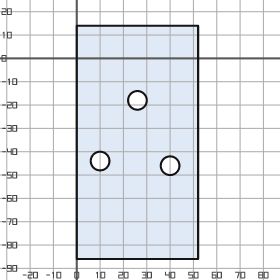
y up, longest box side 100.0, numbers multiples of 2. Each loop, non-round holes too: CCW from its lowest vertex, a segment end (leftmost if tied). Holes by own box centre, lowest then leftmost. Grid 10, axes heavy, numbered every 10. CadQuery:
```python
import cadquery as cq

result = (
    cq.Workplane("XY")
    .moveTo(0.0, -86.0)
    .lineTo(52.0, -86.0)
    .lineTo(52.0, 14.0)
    .lineTo(0.0, 14.0)
    .close()
    .moveTo(40.0, -46.0)
    .circle(4.0)
    .moveTo(10.0, -44.0)
    .circle(4.0)
    .moveTo(26.0, -18.0)
    .circle(4.0)
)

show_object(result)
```